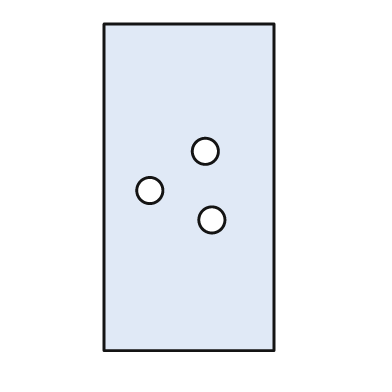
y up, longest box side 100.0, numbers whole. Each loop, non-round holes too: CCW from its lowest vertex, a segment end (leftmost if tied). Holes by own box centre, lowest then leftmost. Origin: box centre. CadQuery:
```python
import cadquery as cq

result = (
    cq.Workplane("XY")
    .moveTo(-26.0, -50.0)
    .lineTo(26.0, -50.0)
    .lineTo(26.0, 50.0)
    .lineTo(-26.0, 50.0)
    .close()
    .moveTo(7.0, -10.0)
    .circle(4.0)
    .moveTo(-12.0, -1.0)
    .circle(4.0)
    .moveTo(5.0, 11.0)
    .circle(4.0)
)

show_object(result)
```